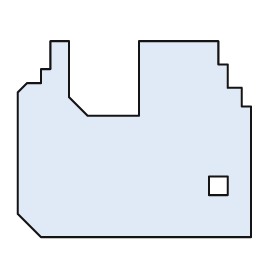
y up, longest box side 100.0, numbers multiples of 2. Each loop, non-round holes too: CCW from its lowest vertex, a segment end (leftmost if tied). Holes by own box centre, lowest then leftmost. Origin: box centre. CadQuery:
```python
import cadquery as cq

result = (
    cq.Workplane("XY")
    .moveTo(-40.0, -42.0)
    .lineTo(50.0, -42.0)
    .lineTo(50.0, 14.0)
    .lineTo(46.0, 14.0)
    .lineTo(46.0, 22.0)
    .lineTo(40.0, 22.0)
    .lineTo(40.0, 32.0)
    .lineTo(36.0, 32.0)
    .lineTo(36.0, 42.0)
    .lineTo(2.0, 42.0)
    .lineTo(2.0, 10.0)
    .lineTo(-20.0, 10.0)
    .lineTo(-28.0, 18.0)
    .lineTo(-28.0, 42.0)
    .lineTo(-36.0, 42.0)
    .lineTo(-36.0, 30.0)
    .lineTo(-40.0, 30.0)
    .lineTo(-40.0, 24.0)
    .lineTo(-46.0, 24.0)
    .lineTo(-50.0, 20.0)
    .lineTo(-50.0, -32.0)
    .close()
    .moveTo(32.0, -24.0)
    .lineTo(40.0, -24.0)
    .lineTo(40.0, -16.0)
    .lineTo(32.0, -16.0)
    .close()
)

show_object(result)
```